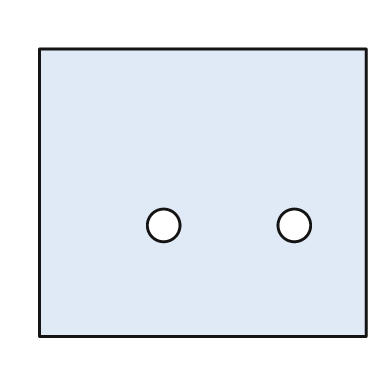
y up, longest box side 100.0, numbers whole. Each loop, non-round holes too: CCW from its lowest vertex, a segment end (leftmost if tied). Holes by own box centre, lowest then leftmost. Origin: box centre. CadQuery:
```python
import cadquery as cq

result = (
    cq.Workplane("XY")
    .moveTo(-50.0, -44.0)
    .lineTo(50.0, -44.0)
    .lineTo(50.0, 44.0)
    .lineTo(-50.0, 44.0)
    .close()
    .moveTo(-12.0, -10.0)
    .circle(5.0)
    .moveTo(28.0, -10.0)
    .circle(5.0)
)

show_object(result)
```